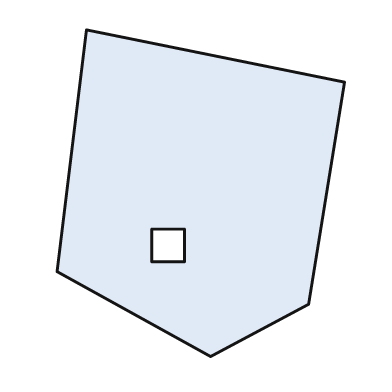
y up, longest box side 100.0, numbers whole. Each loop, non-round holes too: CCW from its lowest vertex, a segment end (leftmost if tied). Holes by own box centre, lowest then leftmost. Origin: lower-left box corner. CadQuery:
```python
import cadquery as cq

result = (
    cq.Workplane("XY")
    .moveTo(47.0, 0.0)
    .lineTo(77.0, 16.0)
    .lineTo(88.0, 84.0)
    .lineTo(9.0, 100.0)
    .lineTo(0.0, 26.0)
    .close()
    .moveTo(29.0, 29.0)
    .lineTo(39.0, 29.0)
    .lineTo(39.0, 39.0)
    .lineTo(29.0, 39.0)
    .close()
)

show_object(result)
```